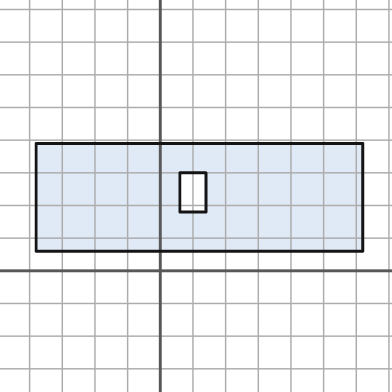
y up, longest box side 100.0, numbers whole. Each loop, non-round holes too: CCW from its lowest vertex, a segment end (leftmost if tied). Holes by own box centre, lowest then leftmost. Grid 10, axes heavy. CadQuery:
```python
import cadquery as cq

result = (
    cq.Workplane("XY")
    .moveTo(-38.0, 6.0)
    .lineTo(62.0, 6.0)
    .lineTo(62.0, 39.0)
    .lineTo(-38.0, 39.0)
    .close()
    .moveTo(6.0, 18.0)
    .lineTo(14.0, 18.0)
    .lineTo(14.0, 30.0)
    .lineTo(6.0, 30.0)
    .close()
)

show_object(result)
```